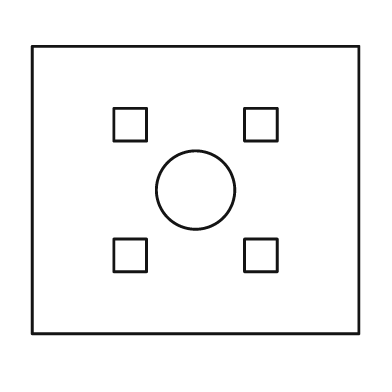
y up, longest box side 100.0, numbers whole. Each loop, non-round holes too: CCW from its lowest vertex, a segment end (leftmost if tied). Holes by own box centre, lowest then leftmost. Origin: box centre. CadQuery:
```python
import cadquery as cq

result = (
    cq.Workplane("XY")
    .moveTo(-50.0, -44.0)
    .lineTo(50.0, -44.0)
    .lineTo(50.0, 44.0)
    .lineTo(-50.0, 44.0)
    .close()
    .moveTo(-25.0, -25.0)
    .lineTo(-15.0, -25.0)
    .lineTo(-15.0, -15.0)
    .lineTo(-25.0, -15.0)
    .close()
    .moveTo(15.0, -25.0)
    .lineTo(25.0, -25.0)
    .lineTo(25.0, -15.0)
    .lineTo(15.0, -15.0)
    .close()
    .moveTo(0.0, 0.0)
    .circle(12.0)
    .moveTo(-25.0, 15.0)
    .lineTo(-15.0, 15.0)
    .lineTo(-15.0, 25.0)
    .lineTo(-25.0, 25.0)
    .close()
    .moveTo(15.0, 15.0)
    .lineTo(25.0, 15.0)
    .lineTo(25.0, 25.0)
    .lineTo(15.0, 25.0)
    .close()
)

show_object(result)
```